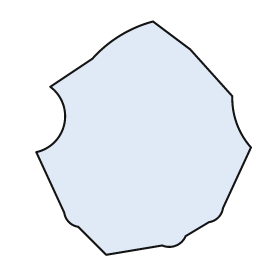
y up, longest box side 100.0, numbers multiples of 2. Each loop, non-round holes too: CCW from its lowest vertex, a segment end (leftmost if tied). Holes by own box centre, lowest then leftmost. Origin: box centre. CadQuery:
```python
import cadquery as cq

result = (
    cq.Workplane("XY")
    .moveTo(-16.0, -50.0)
    .lineTo(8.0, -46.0)
    .threePointArc((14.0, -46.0), (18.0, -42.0))
    .lineTo(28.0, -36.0)
    .threePointArc((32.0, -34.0), (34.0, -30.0))
    .lineTo(46.0, -4.0)
    .threePointArc((40.0, 6.0), (38.0, 18.0))
    .lineTo(20.0, 38.0)
    .lineTo(4.0, 50.0)
    .threePointArc((-10.0, 44.0), (-22.0, 34.0))
    .lineTo(-40.0, 22.0)
    .threePointArc((-34.0, 6.0), (-46.0, -6.0))
    .lineTo(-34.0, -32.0)
    .threePointArc((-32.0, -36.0), (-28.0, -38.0))
    .close()
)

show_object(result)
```